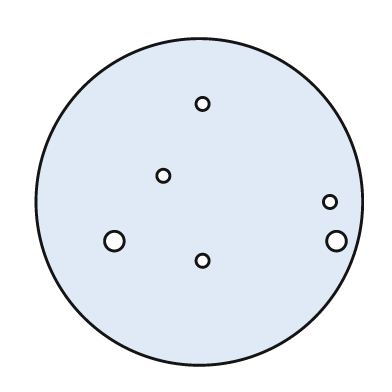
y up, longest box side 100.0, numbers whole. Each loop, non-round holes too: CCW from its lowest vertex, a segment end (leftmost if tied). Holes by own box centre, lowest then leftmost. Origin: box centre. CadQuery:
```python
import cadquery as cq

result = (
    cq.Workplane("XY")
    .moveTo(0.0, 0.0)
    .circle(50.0)
    .moveTo(1.0, -18.0)
    .circle(2.0)
    .moveTo(-26.0, -12.0)
    .circle(3.0)
    .moveTo(42.0, -12.0)
    .circle(3.0)
    .moveTo(40.0, 0.0)
    .circle(2.0)
    .moveTo(-11.0, 8.0)
    .circle(2.0)
    .moveTo(1.0, 30.0)
    .circle(2.0)
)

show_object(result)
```